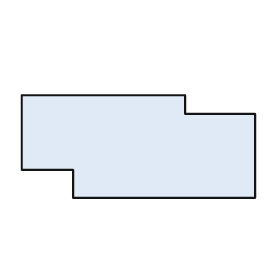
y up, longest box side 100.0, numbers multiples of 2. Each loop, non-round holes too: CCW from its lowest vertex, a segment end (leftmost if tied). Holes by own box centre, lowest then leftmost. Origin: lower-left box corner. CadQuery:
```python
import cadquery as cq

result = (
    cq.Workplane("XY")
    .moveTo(22.0, 0.0)
    .lineTo(100.0, 0.0)
    .lineTo(100.0, 36.0)
    .lineTo(70.0, 36.0)
    .lineTo(70.0, 44.0)
    .lineTo(0.0, 44.0)
    .lineTo(0.0, 12.0)
    .lineTo(22.0, 12.0)
    .close()
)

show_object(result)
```